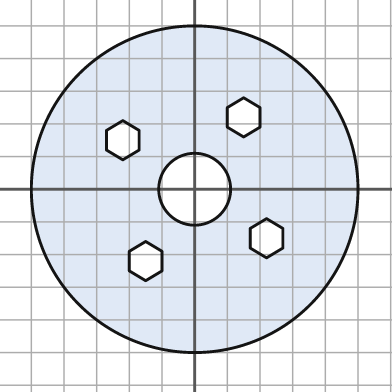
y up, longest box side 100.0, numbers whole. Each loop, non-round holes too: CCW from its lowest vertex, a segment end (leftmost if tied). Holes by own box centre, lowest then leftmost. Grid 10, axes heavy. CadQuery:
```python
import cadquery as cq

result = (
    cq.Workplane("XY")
    .moveTo(0.0, 0.0)
    .circle(50.0)
    .moveTo(-15.0, -28.0)
    .lineTo(-10.0, -25.0)
    .lineTo(-10.0, -19.0)
    .lineTo(-15.0, -16.0)
    .lineTo(-20.0, -19.0)
    .lineTo(-20.0, -25.0)
    .close()
    .moveTo(22.0, -21.0)
    .lineTo(27.0, -18.0)
    .lineTo(27.0, -12.0)
    .lineTo(22.0, -9.0)
    .lineTo(17.0, -12.0)
    .lineTo(17.0, -18.0)
    .close()
    .moveTo(0.0, 0.0)
    .circle(11.0)
    .moveTo(-22.0, 9.0)
    .lineTo(-17.0, 12.0)
    .lineTo(-17.0, 18.0)
    .lineTo(-22.0, 21.0)
    .lineTo(-27.0, 18.0)
    .lineTo(-27.0, 12.0)
    .close()
    .moveTo(15.0, 16.0)
    .lineTo(20.0, 19.0)
    .lineTo(20.0, 25.0)
    .lineTo(15.0, 28.0)
    .lineTo(10.0, 25.0)
    .lineTo(10.0, 19.0)
    .close()
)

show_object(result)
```